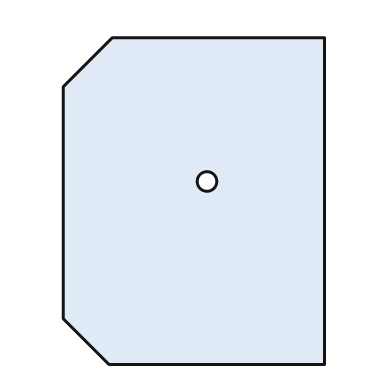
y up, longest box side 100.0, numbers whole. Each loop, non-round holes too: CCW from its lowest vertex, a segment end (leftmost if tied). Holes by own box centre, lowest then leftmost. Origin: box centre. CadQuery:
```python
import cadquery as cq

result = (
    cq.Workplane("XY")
    .moveTo(-26.0, -50.0)
    .lineTo(40.0, -50.0)
    .lineTo(40.0, 50.0)
    .lineTo(-25.0, 50.0)
    .lineTo(-40.0, 35.0)
    .lineTo(-40.0, -36.0)
    .close()
    .moveTo(4.0, 6.0)
    .circle(3.0)
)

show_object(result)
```